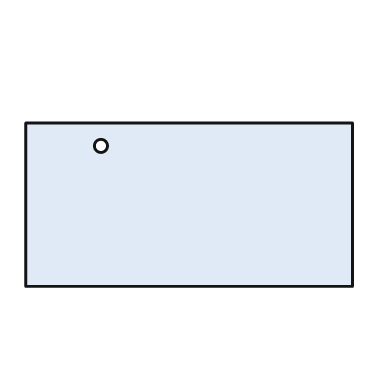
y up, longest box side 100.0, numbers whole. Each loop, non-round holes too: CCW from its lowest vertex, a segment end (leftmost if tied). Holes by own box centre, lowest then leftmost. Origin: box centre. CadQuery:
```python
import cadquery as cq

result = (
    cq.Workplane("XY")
    .moveTo(-50.0, -25.0)
    .lineTo(50.0, -25.0)
    .lineTo(50.0, 25.0)
    .lineTo(-50.0, 25.0)
    .close()
    .moveTo(-27.0, 18.0)
    .circle(2.0)
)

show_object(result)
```